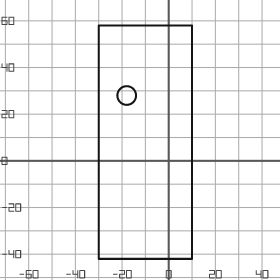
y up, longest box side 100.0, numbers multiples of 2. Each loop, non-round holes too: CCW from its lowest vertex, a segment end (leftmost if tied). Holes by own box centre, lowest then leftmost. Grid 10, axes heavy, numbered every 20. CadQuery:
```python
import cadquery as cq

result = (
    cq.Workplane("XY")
    .moveTo(-30.0, -42.0)
    .lineTo(10.0, -42.0)
    .lineTo(10.0, 58.0)
    .lineTo(-30.0, 58.0)
    .close()
    .moveTo(-18.0, 28.0)
    .circle(4.0)
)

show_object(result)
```